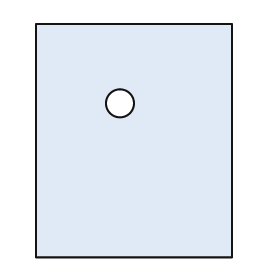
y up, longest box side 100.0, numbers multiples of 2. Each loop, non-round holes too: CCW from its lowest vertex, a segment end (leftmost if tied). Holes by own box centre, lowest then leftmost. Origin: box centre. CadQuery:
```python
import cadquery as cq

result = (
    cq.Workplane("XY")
    .moveTo(-42.0, -50.0)
    .lineTo(42.0, -50.0)
    .lineTo(42.0, 50.0)
    .lineTo(-42.0, 50.0)
    .close()
    .moveTo(-6.0, 16.0)
    .circle(6.0)
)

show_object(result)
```